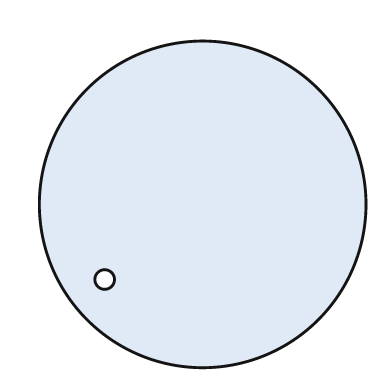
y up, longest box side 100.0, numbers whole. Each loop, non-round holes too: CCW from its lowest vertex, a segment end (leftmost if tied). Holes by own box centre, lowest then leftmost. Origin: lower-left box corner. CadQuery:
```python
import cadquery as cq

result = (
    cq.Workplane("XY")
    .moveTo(50.0, 50.0)
    .circle(50.0)
    .moveTo(20.0, 27.0)
    .circle(3.0)
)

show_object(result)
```